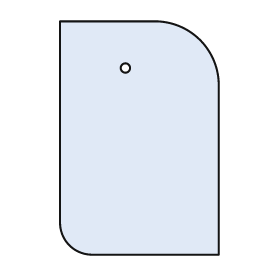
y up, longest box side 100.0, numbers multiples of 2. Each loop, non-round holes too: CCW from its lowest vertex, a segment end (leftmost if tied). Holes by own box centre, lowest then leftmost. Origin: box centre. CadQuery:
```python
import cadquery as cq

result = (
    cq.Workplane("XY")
    .moveTo(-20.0, -50.0)
    .lineTo(34.0, -50.0)
    .lineTo(34.0, 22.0)
    .threePointArc((26.0, 42.0), (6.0, 50.0))
    .lineTo(-34.0, 50.0)
    .lineTo(-34.0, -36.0)
    .threePointArc((-30.0, -46.0), (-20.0, -50.0))
    .close()
    .moveTo(-6.0, 30.0)
    .circle(2.0)
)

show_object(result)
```